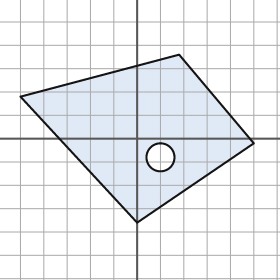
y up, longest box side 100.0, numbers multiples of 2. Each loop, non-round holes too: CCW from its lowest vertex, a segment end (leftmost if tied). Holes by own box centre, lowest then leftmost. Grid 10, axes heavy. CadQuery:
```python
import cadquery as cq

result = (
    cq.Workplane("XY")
    .moveTo(0.0, -36.0)
    .lineTo(50.0, -2.0)
    .lineTo(18.0, 36.0)
    .lineTo(-50.0, 18.0)
    .close()
    .moveTo(10.0, -8.0)
    .circle(6.0)
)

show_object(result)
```